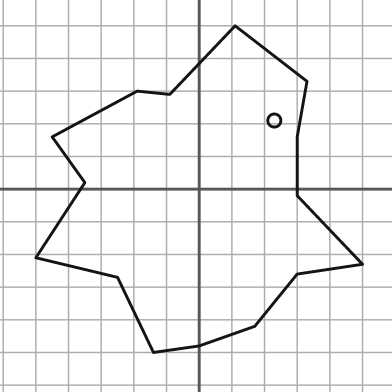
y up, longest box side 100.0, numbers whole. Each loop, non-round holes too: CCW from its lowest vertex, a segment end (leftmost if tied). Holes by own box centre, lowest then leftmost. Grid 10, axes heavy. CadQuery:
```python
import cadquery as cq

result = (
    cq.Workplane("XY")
    .moveTo(-14.0, -50.0)
    .lineTo(0.0, -48.0)
    .lineTo(17.0, -42.0)
    .lineTo(30.0, -26.0)
    .lineTo(50.0, -23.0)
    .lineTo(30.0, -2.0)
    .lineTo(30.0, 16.0)
    .lineTo(33.0, 33.0)
    .lineTo(11.0, 50.0)
    .lineTo(-9.0, 29.0)
    .lineTo(-19.0, 30.0)
    .lineTo(-45.0, 16.0)
    .lineTo(-35.0, 2.0)
    .lineTo(-50.0, -21.0)
    .lineTo(-25.0, -27.0)
    .close()
    .moveTo(23.0, 21.0)
    .circle(2.0)
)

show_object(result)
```